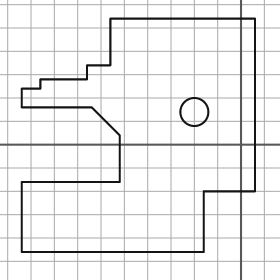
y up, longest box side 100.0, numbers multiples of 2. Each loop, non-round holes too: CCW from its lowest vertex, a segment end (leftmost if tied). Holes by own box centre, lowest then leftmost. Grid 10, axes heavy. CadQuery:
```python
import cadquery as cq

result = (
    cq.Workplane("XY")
    .moveTo(-94.0, -46.0)
    .lineTo(-16.0, -46.0)
    .lineTo(-16.0, -20.0)
    .lineTo(6.0, -20.0)
    .lineTo(6.0, 54.0)
    .lineTo(-56.0, 54.0)
    .lineTo(-56.0, 34.0)
    .lineTo(-66.0, 34.0)
    .lineTo(-66.0, 28.0)
    .lineTo(-86.0, 28.0)
    .lineTo(-86.0, 24.0)
    .lineTo(-94.0, 24.0)
    .lineTo(-94.0, 16.0)
    .lineTo(-64.0, 16.0)
    .lineTo(-52.0, 4.0)
    .lineTo(-52.0, -16.0)
    .lineTo(-94.0, -16.0)
    .close()
    .moveTo(-20.0, 14.0)
    .circle(6.0)
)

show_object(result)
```